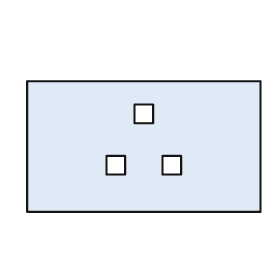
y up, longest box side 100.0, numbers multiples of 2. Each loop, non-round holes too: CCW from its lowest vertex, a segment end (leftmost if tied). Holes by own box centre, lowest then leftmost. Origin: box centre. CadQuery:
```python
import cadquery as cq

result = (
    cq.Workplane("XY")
    .moveTo(-50.0, -28.0)
    .lineTo(50.0, -28.0)
    .lineTo(50.0, 28.0)
    .lineTo(-50.0, 28.0)
    .close()
    .moveTo(-16.0, -12.0)
    .lineTo(-8.0, -12.0)
    .lineTo(-8.0, -4.0)
    .lineTo(-16.0, -4.0)
    .close()
    .moveTo(8.0, -12.0)
    .lineTo(16.0, -12.0)
    .lineTo(16.0, -4.0)
    .lineTo(8.0, -4.0)
    .close()
    .moveTo(-4.0, 10.0)
    .lineTo(4.0, 10.0)
    .lineTo(4.0, 18.0)
    .lineTo(-4.0, 18.0)
    .close()
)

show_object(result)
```